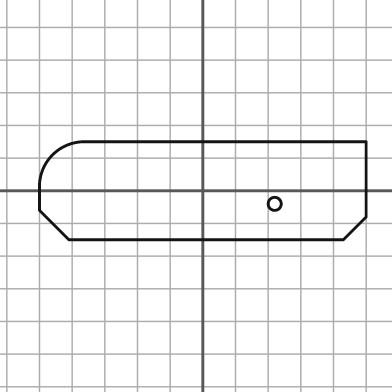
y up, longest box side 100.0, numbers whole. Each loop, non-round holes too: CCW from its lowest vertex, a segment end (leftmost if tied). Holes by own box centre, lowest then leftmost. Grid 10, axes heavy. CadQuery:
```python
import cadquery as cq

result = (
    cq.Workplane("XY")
    .moveTo(-41.0, -15.0)
    .lineTo(43.0, -15.0)
    .lineTo(50.0, -8.0)
    .lineTo(50.0, 15.0)
    .lineTo(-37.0, 15.0)
    .threePointArc((-46.0, 11.0), (-50.0, 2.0))
    .lineTo(-50.0, -6.0)
    .close()
    .moveTo(22.0, -4.0)
    .circle(2.0)
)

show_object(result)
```